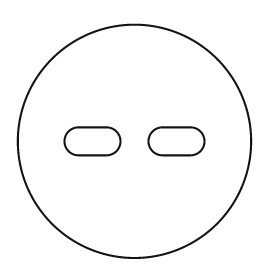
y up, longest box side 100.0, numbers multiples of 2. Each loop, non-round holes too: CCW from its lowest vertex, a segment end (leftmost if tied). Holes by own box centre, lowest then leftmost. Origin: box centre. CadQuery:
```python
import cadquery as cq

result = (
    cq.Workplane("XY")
    .moveTo(0.0, 0.0)
    .circle(50.0)
    .moveTo(-24.0, -6.0)
    .lineTo(-12.0, -6.0)
    .threePointArc((-6.0, 0.0), (-12.0, 6.0))
    .lineTo(-24.0, 6.0)
    .threePointArc((-30.0, 0.0), (-24.0, -6.0))
    .close()
    .moveTo(12.0, -6.0)
    .lineTo(24.0, -6.0)
    .threePointArc((30.0, 0.0), (24.0, 6.0))
    .lineTo(12.0, 6.0)
    .threePointArc((6.0, 0.0), (12.0, -6.0))
    .close()
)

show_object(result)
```